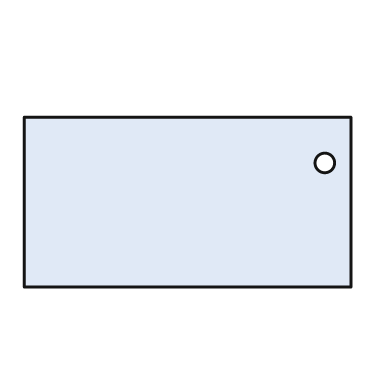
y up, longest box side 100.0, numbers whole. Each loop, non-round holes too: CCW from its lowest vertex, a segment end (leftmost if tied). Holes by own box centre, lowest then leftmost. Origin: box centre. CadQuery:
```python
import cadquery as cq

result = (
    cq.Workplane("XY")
    .moveTo(-50.0, -26.0)
    .lineTo(50.0, -26.0)
    .lineTo(50.0, 26.0)
    .lineTo(-50.0, 26.0)
    .close()
    .moveTo(42.0, 12.0)
    .circle(3.0)
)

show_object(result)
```